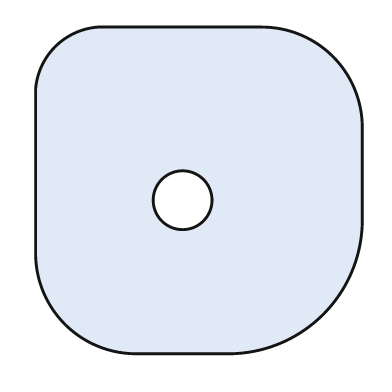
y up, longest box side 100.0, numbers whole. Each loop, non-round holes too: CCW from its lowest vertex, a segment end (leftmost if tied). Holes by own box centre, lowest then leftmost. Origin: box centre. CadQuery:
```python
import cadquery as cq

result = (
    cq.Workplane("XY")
    .moveTo(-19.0, -50.0)
    .lineTo(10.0, -50.0)
    .threePointArc((38.0, -38.0), (50.0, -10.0))
    .lineTo(50.0, 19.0)
    .threePointArc((41.0, 41.0), (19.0, 50.0))
    .lineTo(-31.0, 50.0)
    .threePointArc((-44.0, 44.0), (-50.0, 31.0))
    .lineTo(-50.0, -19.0)
    .threePointArc((-41.0, -41.0), (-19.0, -50.0))
    .close()
    .moveTo(-5.0, -3.0)
    .circle(9.0)
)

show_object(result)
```